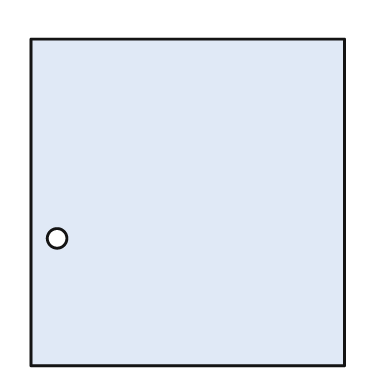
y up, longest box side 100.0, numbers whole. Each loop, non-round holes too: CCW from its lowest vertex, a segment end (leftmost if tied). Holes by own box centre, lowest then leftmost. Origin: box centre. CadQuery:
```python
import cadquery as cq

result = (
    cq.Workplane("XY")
    .moveTo(-48.0, -50.0)
    .lineTo(48.0, -50.0)
    .lineTo(48.0, 50.0)
    .lineTo(-48.0, 50.0)
    .close()
    .moveTo(-40.0, -11.0)
    .circle(3.0)
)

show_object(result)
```